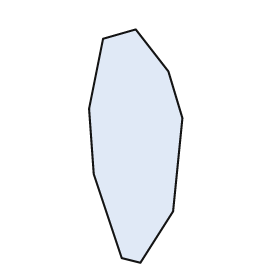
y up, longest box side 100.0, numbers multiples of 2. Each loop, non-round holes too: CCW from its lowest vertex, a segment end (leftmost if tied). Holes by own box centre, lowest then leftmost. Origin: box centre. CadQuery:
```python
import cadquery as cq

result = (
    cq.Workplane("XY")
    .moveTo(2.0, -50.0)
    .lineTo(16.0, -28.0)
    .lineTo(20.0, 12.0)
    .lineTo(14.0, 32.0)
    .lineTo(0.0, 50.0)
    .lineTo(-14.0, 46.0)
    .lineTo(-20.0, 16.0)
    .lineTo(-18.0, -12.0)
    .lineTo(-6.0, -48.0)
    .close()
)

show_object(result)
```